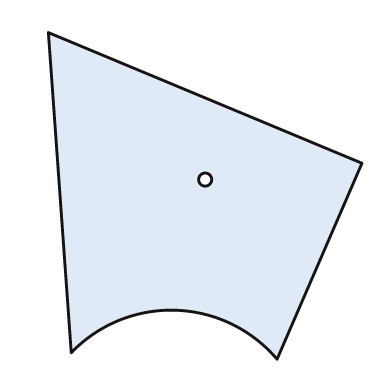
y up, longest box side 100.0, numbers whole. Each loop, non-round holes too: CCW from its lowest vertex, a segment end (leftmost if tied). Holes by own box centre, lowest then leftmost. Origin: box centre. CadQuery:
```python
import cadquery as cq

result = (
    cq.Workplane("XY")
    .moveTo(22.0, -50.0)
    .lineTo(48.0, 10.0)
    .lineTo(-48.0, 50.0)
    .lineTo(-41.0, -48.0)
    .threePointArc((-9.0, -35.0), (22.0, -50.0))
    .close()
    .moveTo(0.0, 5.0)
    .circle(2.0)
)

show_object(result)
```